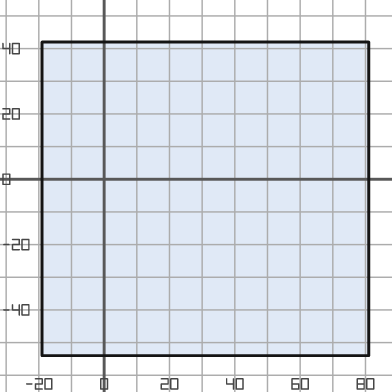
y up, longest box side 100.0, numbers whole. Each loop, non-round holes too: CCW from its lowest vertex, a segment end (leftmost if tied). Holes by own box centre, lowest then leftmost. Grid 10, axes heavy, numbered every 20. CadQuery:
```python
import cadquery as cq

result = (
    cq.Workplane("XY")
    .moveTo(-19.0, -54.0)
    .lineTo(81.0, -54.0)
    .lineTo(81.0, 42.0)
    .lineTo(-19.0, 42.0)
    .close()
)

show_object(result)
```